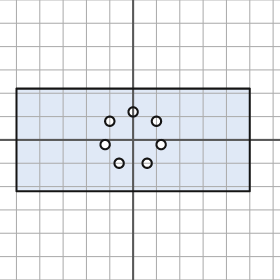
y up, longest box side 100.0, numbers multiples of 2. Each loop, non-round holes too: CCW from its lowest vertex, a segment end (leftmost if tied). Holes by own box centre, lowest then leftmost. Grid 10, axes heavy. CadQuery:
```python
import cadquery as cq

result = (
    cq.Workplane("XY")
    .moveTo(-50.0, -22.0)
    .lineTo(50.0, -22.0)
    .lineTo(50.0, 22.0)
    .lineTo(-50.0, 22.0)
    .close()
    .moveTo(-6.0, -10.0)
    .circle(2.0)
    .moveTo(6.0, -10.0)
    .circle(2.0)
    .moveTo(-12.0, -2.0)
    .circle(2.0)
    .moveTo(12.0, -2.0)
    .circle(2.0)
    .moveTo(-10.0, 8.0)
    .circle(2.0)
    .moveTo(10.0, 8.0)
    .circle(2.0)
    .moveTo(0.0, 12.0)
    .circle(2.0)
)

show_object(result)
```